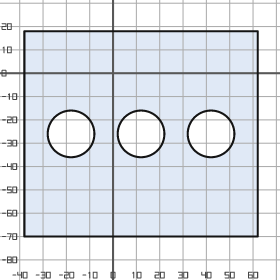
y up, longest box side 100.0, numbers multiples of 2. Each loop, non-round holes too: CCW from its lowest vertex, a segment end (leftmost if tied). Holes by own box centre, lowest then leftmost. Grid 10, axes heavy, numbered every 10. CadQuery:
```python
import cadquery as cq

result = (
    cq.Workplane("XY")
    .moveTo(-38.0, -70.0)
    .lineTo(62.0, -70.0)
    .lineTo(62.0, 18.0)
    .lineTo(-38.0, 18.0)
    .close()
    .moveTo(-18.0, -26.0)
    .circle(10.0)
    .moveTo(12.0, -26.0)
    .circle(10.0)
    .moveTo(42.0, -26.0)
    .circle(10.0)
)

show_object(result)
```